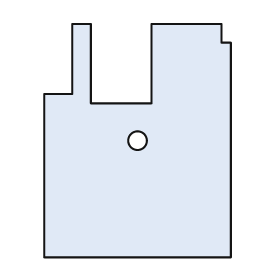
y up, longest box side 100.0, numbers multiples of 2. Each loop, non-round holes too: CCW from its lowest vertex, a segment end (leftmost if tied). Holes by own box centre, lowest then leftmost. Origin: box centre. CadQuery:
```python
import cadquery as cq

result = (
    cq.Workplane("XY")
    .moveTo(-40.0, -50.0)
    .lineTo(40.0, -50.0)
    .lineTo(40.0, 42.0)
    .lineTo(36.0, 42.0)
    .lineTo(36.0, 50.0)
    .lineTo(6.0, 50.0)
    .lineTo(6.0, 16.0)
    .lineTo(-20.0, 16.0)
    .lineTo(-20.0, 50.0)
    .lineTo(-28.0, 50.0)
    .lineTo(-28.0, 20.0)
    .lineTo(-40.0, 20.0)
    .close()
    .moveTo(0.0, 0.0)
    .circle(4.0)
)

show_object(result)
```